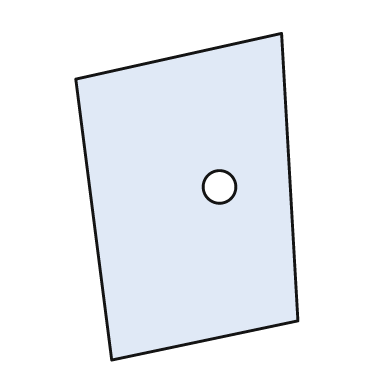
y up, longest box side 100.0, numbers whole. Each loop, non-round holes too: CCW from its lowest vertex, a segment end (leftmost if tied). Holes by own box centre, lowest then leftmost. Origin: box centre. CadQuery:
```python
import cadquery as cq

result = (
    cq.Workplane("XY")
    .moveTo(-23.0, -50.0)
    .lineTo(34.0, -38.0)
    .lineTo(29.0, 50.0)
    .lineTo(-34.0, 36.0)
    .close()
    .moveTo(10.0, 3.0)
    .circle(5.0)
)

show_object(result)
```